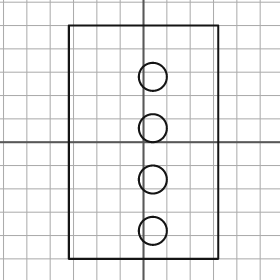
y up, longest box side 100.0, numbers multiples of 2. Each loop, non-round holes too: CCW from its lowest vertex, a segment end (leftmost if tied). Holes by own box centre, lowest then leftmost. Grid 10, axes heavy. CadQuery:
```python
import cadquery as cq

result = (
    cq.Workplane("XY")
    .moveTo(-32.0, -50.0)
    .lineTo(32.0, -50.0)
    .lineTo(32.0, 50.0)
    .lineTo(-32.0, 50.0)
    .close()
    .moveTo(4.0, -38.0)
    .circle(6.0)
    .moveTo(4.0, -16.0)
    .circle(6.0)
    .moveTo(4.0, 6.0)
    .circle(6.0)
    .moveTo(4.0, 28.0)
    .circle(6.0)
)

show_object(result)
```